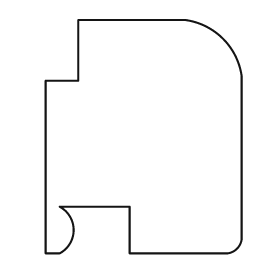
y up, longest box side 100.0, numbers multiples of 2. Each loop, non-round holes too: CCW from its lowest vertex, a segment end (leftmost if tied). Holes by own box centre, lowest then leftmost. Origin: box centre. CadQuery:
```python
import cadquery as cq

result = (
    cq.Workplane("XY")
    .moveTo(-42.0, -50.0)
    .lineTo(-36.0, -50.0)
    .threePointArc((-30.0, -40.0), (-36.0, -30.0))
    .lineTo(-6.0, -30.0)
    .lineTo(-6.0, -50.0)
    .lineTo(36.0, -50.0)
    .threePointArc((40.0, -48.0), (42.0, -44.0))
    .lineTo(42.0, 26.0)
    .threePointArc((34.0, 42.0), (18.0, 50.0))
    .lineTo(-28.0, 50.0)
    .lineTo(-28.0, 24.0)
    .lineTo(-42.0, 24.0)
    .close()
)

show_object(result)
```